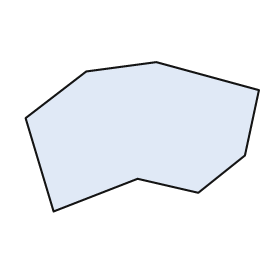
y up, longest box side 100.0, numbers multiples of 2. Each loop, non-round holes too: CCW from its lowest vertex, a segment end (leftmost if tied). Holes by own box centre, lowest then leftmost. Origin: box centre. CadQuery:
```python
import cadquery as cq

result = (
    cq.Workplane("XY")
    .moveTo(-38.0, -32.0)
    .lineTo(-2.0, -18.0)
    .lineTo(24.0, -24.0)
    .lineTo(44.0, -8.0)
    .lineTo(50.0, 20.0)
    .lineTo(6.0, 32.0)
    .lineTo(-24.0, 28.0)
    .lineTo(-50.0, 8.0)
    .close()
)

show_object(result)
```